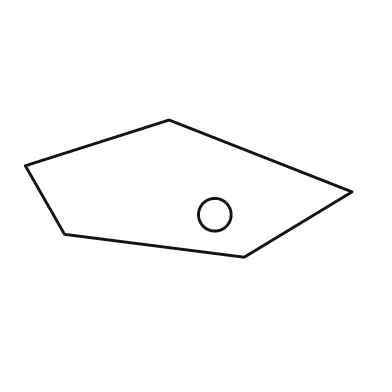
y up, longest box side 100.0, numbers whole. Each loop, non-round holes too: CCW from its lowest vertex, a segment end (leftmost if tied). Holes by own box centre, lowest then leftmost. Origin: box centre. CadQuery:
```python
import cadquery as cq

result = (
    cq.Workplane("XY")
    .moveTo(17.0, -21.0)
    .lineTo(50.0, -1.0)
    .lineTo(-6.0, 21.0)
    .lineTo(-50.0, 7.0)
    .lineTo(-38.0, -14.0)
    .close()
    .moveTo(8.0, -8.0)
    .circle(5.0)
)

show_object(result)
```